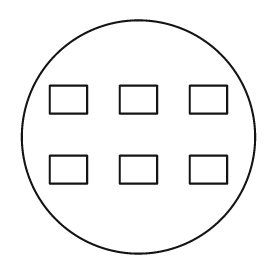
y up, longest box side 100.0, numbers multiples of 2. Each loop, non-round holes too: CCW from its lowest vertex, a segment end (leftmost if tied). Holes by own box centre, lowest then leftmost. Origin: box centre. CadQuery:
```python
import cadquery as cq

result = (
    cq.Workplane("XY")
    .moveTo(0.0, 0.0)
    .circle(50.0)
    .moveTo(-38.0, -20.0)
    .lineTo(-22.0, -20.0)
    .lineTo(-22.0, -8.0)
    .lineTo(-38.0, -8.0)
    .close()
    .moveTo(-8.0, -20.0)
    .lineTo(8.0, -20.0)
    .lineTo(8.0, -8.0)
    .lineTo(-8.0, -8.0)
    .close()
    .moveTo(22.0, -20.0)
    .lineTo(38.0, -20.0)
    .lineTo(38.0, -8.0)
    .lineTo(22.0, -8.0)
    .close()
    .moveTo(-38.0, 10.0)
    .lineTo(-22.0, 10.0)
    .lineTo(-22.0, 22.0)
    .lineTo(-38.0, 22.0)
    .close()
    .moveTo(-8.0, 10.0)
    .lineTo(8.0, 10.0)
    .lineTo(8.0, 22.0)
    .lineTo(-8.0, 22.0)
    .close()
    .moveTo(22.0, 10.0)
    .lineTo(38.0, 10.0)
    .lineTo(38.0, 22.0)
    .lineTo(22.0, 22.0)
    .close()
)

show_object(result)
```